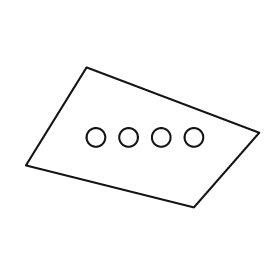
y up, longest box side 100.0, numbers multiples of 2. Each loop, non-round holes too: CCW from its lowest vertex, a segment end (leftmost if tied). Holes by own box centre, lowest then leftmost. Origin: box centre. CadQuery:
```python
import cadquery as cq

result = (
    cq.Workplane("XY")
    .moveTo(22.0, -30.0)
    .lineTo(50.0, 2.0)
    .lineTo(-24.0, 30.0)
    .lineTo(-50.0, -12.0)
    .close()
    .moveTo(-20.0, 0.0)
    .circle(4.0)
    .moveTo(-6.0, 0.0)
    .circle(4.0)
    .moveTo(8.0, 0.0)
    .circle(4.0)
    .moveTo(22.0, 0.0)
    .circle(4.0)
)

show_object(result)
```